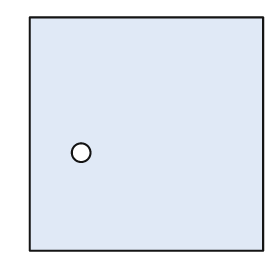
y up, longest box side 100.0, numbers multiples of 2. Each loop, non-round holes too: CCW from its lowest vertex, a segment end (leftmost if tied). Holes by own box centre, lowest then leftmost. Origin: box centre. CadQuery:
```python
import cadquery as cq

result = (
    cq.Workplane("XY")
    .moveTo(-50.0, -50.0)
    .lineTo(50.0, -50.0)
    .lineTo(50.0, 50.0)
    .lineTo(-50.0, 50.0)
    .close()
    .moveTo(-28.0, -8.0)
    .circle(4.0)
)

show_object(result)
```